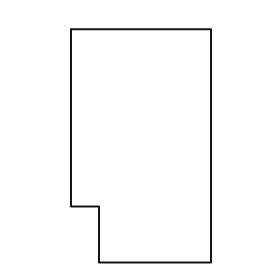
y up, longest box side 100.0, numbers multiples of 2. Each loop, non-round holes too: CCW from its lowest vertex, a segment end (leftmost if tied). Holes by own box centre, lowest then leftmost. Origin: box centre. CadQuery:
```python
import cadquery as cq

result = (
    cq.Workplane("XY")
    .moveTo(-18.0, -50.0)
    .lineTo(30.0, -50.0)
    .lineTo(30.0, 50.0)
    .lineTo(-30.0, 50.0)
    .lineTo(-30.0, -26.0)
    .lineTo(-18.0, -26.0)
    .close()
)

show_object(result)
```